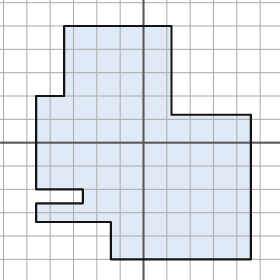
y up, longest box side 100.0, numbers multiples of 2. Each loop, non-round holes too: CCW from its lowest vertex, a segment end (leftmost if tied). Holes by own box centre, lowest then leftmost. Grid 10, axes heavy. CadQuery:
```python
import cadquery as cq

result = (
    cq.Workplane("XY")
    .moveTo(-14.0, -50.0)
    .lineTo(46.0, -50.0)
    .lineTo(46.0, 12.0)
    .lineTo(12.0, 12.0)
    .lineTo(12.0, 50.0)
    .lineTo(-34.0, 50.0)
    .lineTo(-34.0, 20.0)
    .lineTo(-46.0, 20.0)
    .lineTo(-46.0, -20.0)
    .lineTo(-26.0, -20.0)
    .lineTo(-26.0, -26.0)
    .lineTo(-46.0, -26.0)
    .lineTo(-46.0, -34.0)
    .lineTo(-14.0, -34.0)
    .close()
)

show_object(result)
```